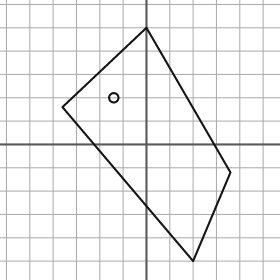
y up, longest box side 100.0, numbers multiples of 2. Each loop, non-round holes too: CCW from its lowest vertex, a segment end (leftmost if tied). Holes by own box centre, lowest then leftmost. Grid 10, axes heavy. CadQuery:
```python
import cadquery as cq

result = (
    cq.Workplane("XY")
    .moveTo(20.0, -50.0)
    .lineTo(36.0, -12.0)
    .lineTo(0.0, 50.0)
    .lineTo(-36.0, 16.0)
    .close()
    .moveTo(-14.0, 20.0)
    .circle(2.0)
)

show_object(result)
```